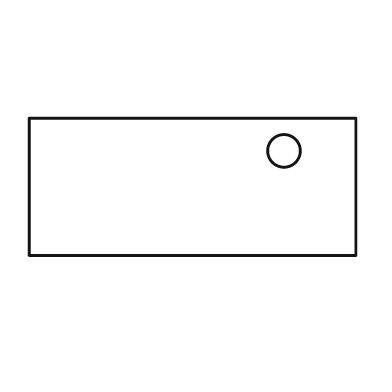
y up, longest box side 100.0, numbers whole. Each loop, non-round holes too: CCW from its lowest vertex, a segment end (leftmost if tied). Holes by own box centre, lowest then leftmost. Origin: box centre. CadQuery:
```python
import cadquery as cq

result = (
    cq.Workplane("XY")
    .moveTo(-50.0, -21.0)
    .lineTo(50.0, -21.0)
    .lineTo(50.0, 21.0)
    .lineTo(-50.0, 21.0)
    .close()
    .moveTo(28.0, 11.0)
    .circle(5.0)
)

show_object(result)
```